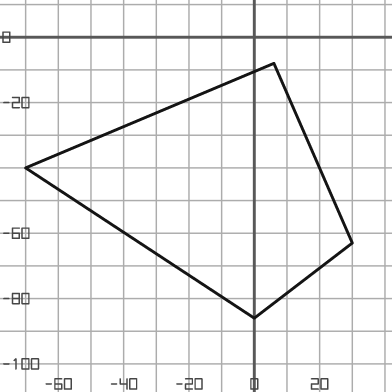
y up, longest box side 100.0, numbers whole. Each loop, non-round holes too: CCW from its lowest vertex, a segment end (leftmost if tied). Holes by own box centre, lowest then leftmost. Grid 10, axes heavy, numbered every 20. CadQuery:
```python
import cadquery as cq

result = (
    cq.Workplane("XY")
    .moveTo(0.0, -86.0)
    .lineTo(30.0, -63.0)
    .lineTo(6.0, -8.0)
    .lineTo(-70.0, -40.0)
    .close()
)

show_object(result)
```